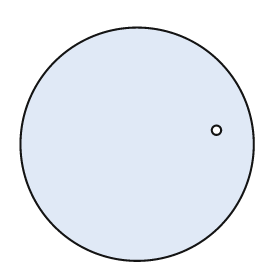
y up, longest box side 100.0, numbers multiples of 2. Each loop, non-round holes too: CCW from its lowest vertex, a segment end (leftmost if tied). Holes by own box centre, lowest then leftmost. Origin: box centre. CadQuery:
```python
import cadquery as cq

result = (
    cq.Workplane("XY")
    .moveTo(0.0, 0.0)
    .circle(50.0)
    .moveTo(34.0, 6.0)
    .circle(2.0)
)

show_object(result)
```